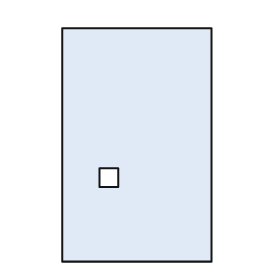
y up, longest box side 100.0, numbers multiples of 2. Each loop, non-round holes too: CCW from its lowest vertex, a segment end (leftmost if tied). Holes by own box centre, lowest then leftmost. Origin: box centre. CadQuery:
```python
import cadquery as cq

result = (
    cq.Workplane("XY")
    .moveTo(-32.0, -50.0)
    .lineTo(32.0, -50.0)
    .lineTo(32.0, 50.0)
    .lineTo(-32.0, 50.0)
    .close()
    .moveTo(-16.0, -18.0)
    .lineTo(-8.0, -18.0)
    .lineTo(-8.0, -10.0)
    .lineTo(-16.0, -10.0)
    .close()
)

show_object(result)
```